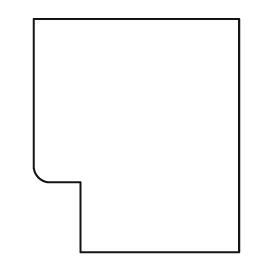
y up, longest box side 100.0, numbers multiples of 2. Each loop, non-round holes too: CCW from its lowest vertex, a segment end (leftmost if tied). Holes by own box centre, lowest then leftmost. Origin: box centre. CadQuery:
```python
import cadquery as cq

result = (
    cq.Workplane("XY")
    .moveTo(-24.0, -50.0)
    .lineTo(44.0, -50.0)
    .lineTo(44.0, 50.0)
    .lineTo(-44.0, 50.0)
    .lineTo(-44.0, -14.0)
    .threePointArc((-42.0, -18.0), (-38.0, -20.0))
    .lineTo(-24.0, -20.0)
    .close()
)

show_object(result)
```